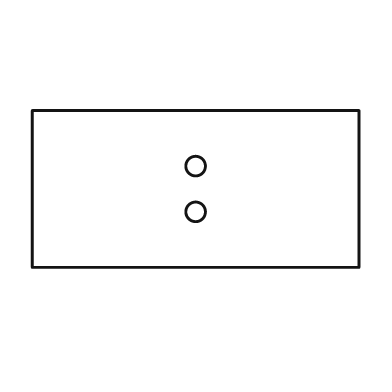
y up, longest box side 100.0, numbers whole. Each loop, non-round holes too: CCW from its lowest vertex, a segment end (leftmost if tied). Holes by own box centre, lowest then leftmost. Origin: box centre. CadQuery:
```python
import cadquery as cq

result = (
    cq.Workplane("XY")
    .moveTo(-50.0, -24.0)
    .lineTo(50.0, -24.0)
    .lineTo(50.0, 24.0)
    .lineTo(-50.0, 24.0)
    .close()
    .moveTo(0.0, -7.0)
    .circle(3.0)
    .moveTo(0.0, 7.0)
    .circle(3.0)
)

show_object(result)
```